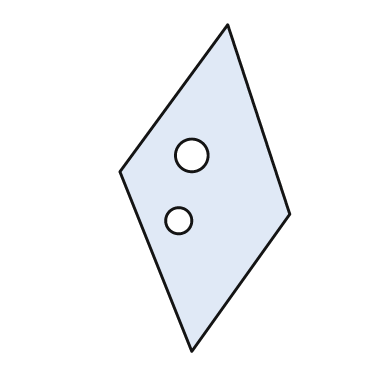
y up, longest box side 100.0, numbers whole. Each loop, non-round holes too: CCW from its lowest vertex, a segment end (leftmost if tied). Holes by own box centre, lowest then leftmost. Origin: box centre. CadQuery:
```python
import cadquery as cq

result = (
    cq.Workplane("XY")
    .moveTo(-4.0, -50.0)
    .lineTo(26.0, -8.0)
    .lineTo(7.0, 50.0)
    .lineTo(-26.0, 5.0)
    .close()
    .moveTo(-8.0, -10.0)
    .circle(4.0)
    .moveTo(-4.0, 10.0)
    .circle(5.0)
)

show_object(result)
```